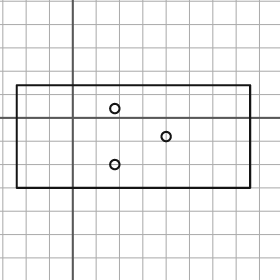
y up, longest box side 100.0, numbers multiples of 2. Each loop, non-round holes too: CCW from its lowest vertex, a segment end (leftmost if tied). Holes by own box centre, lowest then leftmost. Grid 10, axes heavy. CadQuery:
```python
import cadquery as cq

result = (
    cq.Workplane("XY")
    .moveTo(-24.0, -30.0)
    .lineTo(76.0, -30.0)
    .lineTo(76.0, 14.0)
    .lineTo(-24.0, 14.0)
    .close()
    .moveTo(18.0, -20.0)
    .circle(2.0)
    .moveTo(40.0, -8.0)
    .circle(2.0)
    .moveTo(18.0, 4.0)
    .circle(2.0)
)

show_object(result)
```